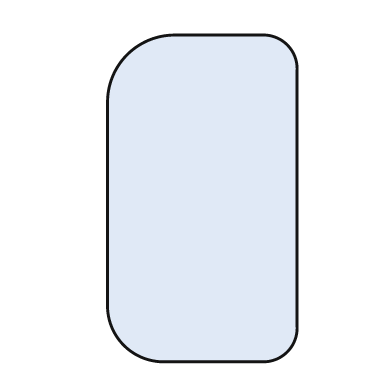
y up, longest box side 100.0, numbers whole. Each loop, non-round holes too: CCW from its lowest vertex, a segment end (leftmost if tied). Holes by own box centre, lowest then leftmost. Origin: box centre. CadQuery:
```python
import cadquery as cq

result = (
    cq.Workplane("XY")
    .moveTo(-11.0, -50.0)
    .lineTo(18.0, -50.0)
    .threePointArc((26.0, -47.0), (29.0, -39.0))
    .lineTo(29.0, 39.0)
    .threePointArc((26.0, 47.0), (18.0, 50.0))
    .lineTo(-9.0, 50.0)
    .threePointArc((-23.0, 44.0), (-29.0, 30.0))
    .lineTo(-29.0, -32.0)
    .threePointArc((-24.0, -45.0), (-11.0, -50.0))
    .close()
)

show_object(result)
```